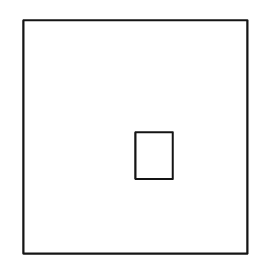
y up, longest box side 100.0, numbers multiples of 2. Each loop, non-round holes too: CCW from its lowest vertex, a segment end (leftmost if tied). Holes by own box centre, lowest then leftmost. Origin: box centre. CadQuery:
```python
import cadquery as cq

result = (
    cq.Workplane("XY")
    .moveTo(-48.0, -50.0)
    .lineTo(48.0, -50.0)
    .lineTo(48.0, 50.0)
    .lineTo(-48.0, 50.0)
    .close()
    .moveTo(0.0, -18.0)
    .lineTo(16.0, -18.0)
    .lineTo(16.0, 2.0)
    .lineTo(0.0, 2.0)
    .close()
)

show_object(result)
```